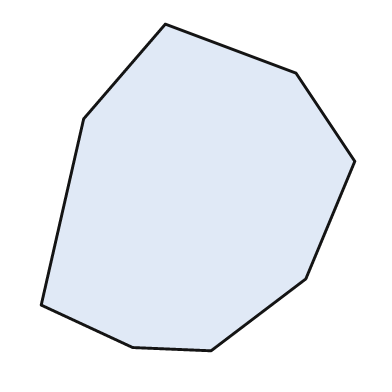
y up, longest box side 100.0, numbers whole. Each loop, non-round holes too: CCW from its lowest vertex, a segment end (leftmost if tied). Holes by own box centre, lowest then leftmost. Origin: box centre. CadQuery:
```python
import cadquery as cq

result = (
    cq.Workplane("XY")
    .moveTo(4.0, -50.0)
    .lineTo(33.0, -28.0)
    .lineTo(48.0, 8.0)
    .lineTo(30.0, 35.0)
    .lineTo(-10.0, 50.0)
    .lineTo(-35.0, 21.0)
    .lineTo(-48.0, -36.0)
    .lineTo(-20.0, -49.0)
    .close()
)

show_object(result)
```